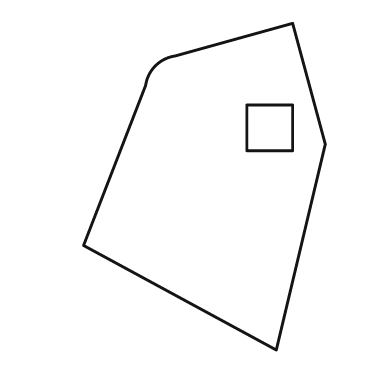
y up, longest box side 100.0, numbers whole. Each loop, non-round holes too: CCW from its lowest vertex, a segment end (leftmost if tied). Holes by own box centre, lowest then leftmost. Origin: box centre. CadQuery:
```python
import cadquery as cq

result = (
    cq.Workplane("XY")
    .moveTo(22.0, -50.0)
    .lineTo(37.0, 13.0)
    .lineTo(27.0, 50.0)
    .lineTo(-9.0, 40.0)
    .threePointArc((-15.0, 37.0), (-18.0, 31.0))
    .lineTo(-37.0, -18.0)
    .close()
    .moveTo(13.0, 11.0)
    .lineTo(27.0, 11.0)
    .lineTo(27.0, 25.0)
    .lineTo(13.0, 25.0)
    .close()
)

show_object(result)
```